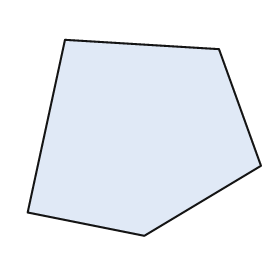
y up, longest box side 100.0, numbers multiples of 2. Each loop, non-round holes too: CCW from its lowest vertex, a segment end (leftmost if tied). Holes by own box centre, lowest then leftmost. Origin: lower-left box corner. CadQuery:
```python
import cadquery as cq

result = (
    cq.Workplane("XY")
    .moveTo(50.0, 0.0)
    .lineTo(100.0, 30.0)
    .lineTo(82.0, 80.0)
    .lineTo(16.0, 84.0)
    .lineTo(0.0, 10.0)
    .close()
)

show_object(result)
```